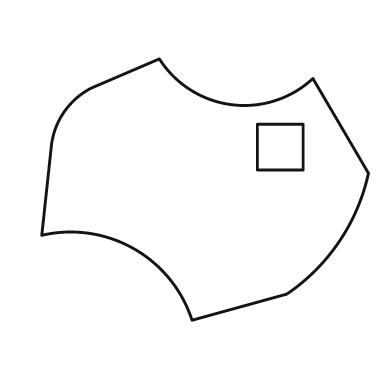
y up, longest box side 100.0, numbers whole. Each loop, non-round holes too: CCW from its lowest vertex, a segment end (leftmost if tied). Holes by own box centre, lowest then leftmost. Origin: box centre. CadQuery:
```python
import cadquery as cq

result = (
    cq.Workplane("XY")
    .moveTo(-4.0, -40.0)
    .lineTo(25.0, -32.0)
    .threePointArc((41.0, -16.0), (50.0, 5.0))
    .lineTo(33.0, 34.0)
    .threePointArc((8.0, 26.0), (-14.0, 40.0))
    .lineTo(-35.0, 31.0)
    .threePointArc((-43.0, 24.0), (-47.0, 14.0))
    .lineTo(-50.0, -14.0)
    .threePointArc((-22.0, -18.0), (-4.0, -40.0))
    .close()
    .moveTo(16.0, 6.0)
    .lineTo(30.0, 6.0)
    .lineTo(30.0, 20.0)
    .lineTo(16.0, 20.0)
    .close()
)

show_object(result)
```